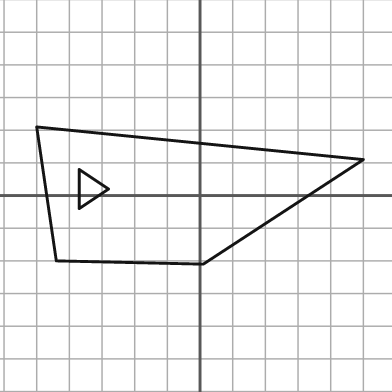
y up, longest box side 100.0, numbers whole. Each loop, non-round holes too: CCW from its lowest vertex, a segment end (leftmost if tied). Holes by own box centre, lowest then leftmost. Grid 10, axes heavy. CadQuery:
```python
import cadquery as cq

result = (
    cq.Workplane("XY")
    .moveTo(1.0, -21.0)
    .lineTo(50.0, 11.0)
    .lineTo(-50.0, 21.0)
    .lineTo(-44.0, -20.0)
    .close()
    .moveTo(-37.0, -4.0)
    .lineTo(-28.0, 2.0)
    .lineTo(-37.0, 8.0)
    .close()
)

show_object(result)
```